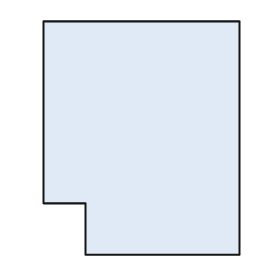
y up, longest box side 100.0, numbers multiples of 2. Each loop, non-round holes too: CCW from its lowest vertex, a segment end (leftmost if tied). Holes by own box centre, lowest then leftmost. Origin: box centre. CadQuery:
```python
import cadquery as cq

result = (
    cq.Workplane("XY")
    .moveTo(-24.0, -50.0)
    .lineTo(42.0, -50.0)
    .lineTo(42.0, 50.0)
    .lineTo(-42.0, 50.0)
    .lineTo(-42.0, -28.0)
    .lineTo(-24.0, -28.0)
    .close()
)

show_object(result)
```